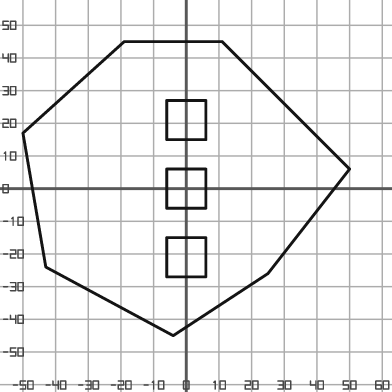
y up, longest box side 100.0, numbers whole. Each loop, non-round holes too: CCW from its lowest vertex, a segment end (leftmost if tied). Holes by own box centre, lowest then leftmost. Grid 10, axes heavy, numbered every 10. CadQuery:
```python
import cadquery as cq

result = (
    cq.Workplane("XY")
    .moveTo(-4.0, -45.0)
    .lineTo(25.0, -26.0)
    .lineTo(50.0, 6.0)
    .lineTo(11.0, 45.0)
    .lineTo(-19.0, 45.0)
    .lineTo(-50.0, 17.0)
    .lineTo(-43.0, -24.0)
    .close()
    .moveTo(-6.0, -27.0)
    .lineTo(6.0, -27.0)
    .lineTo(6.0, -15.0)
    .lineTo(-6.0, -15.0)
    .close()
    .moveTo(-6.0, -6.0)
    .lineTo(6.0, -6.0)
    .lineTo(6.0, 6.0)
    .lineTo(-6.0, 6.0)
    .close()
    .moveTo(-6.0, 15.0)
    .lineTo(6.0, 15.0)
    .lineTo(6.0, 27.0)
    .lineTo(-6.0, 27.0)
    .close()
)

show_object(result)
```